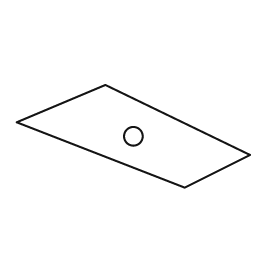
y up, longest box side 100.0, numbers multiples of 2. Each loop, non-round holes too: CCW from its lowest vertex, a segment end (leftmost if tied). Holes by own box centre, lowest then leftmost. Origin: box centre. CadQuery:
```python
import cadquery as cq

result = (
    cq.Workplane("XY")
    .moveTo(22.0, -22.0)
    .lineTo(50.0, -8.0)
    .lineTo(-12.0, 22.0)
    .lineTo(-50.0, 6.0)
    .close()
    .moveTo(0.0, 0.0)
    .circle(4.0)
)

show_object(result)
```